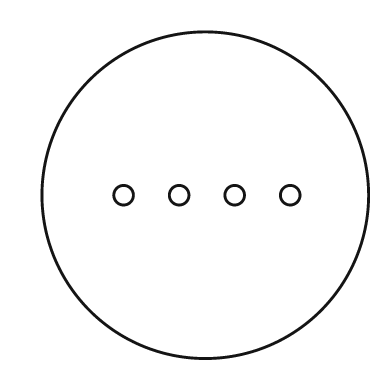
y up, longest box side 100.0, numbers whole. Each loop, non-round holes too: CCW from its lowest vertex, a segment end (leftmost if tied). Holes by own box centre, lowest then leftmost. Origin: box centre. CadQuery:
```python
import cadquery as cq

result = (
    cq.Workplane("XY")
    .moveTo(0.0, 0.0)
    .circle(50.0)
    .moveTo(-25.0, 0.0)
    .circle(3.0)
    .moveTo(-8.0, 0.0)
    .circle(3.0)
    .moveTo(9.0, 0.0)
    .circle(3.0)
    .moveTo(26.0, 0.0)
    .circle(3.0)
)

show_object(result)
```